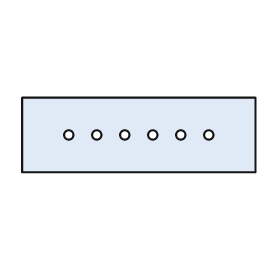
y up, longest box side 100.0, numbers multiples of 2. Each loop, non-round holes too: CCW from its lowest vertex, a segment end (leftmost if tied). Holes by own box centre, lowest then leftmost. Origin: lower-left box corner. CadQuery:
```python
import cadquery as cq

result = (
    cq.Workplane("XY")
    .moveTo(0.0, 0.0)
    .lineTo(100.0, 0.0)
    .lineTo(100.0, 32.0)
    .lineTo(0.0, 32.0)
    .close()
    .moveTo(20.0, 16.0)
    .circle(2.0)
    .moveTo(32.0, 16.0)
    .circle(2.0)
    .moveTo(44.0, 16.0)
    .circle(2.0)
    .moveTo(56.0, 16.0)
    .circle(2.0)
    .moveTo(68.0, 16.0)
    .circle(2.0)
    .moveTo(80.0, 16.0)
    .circle(2.0)
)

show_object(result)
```